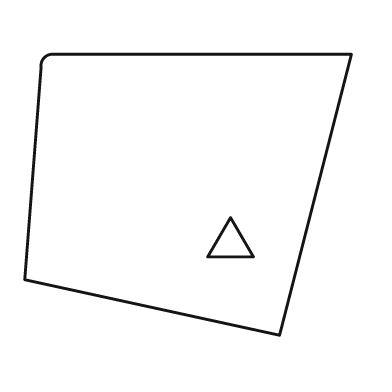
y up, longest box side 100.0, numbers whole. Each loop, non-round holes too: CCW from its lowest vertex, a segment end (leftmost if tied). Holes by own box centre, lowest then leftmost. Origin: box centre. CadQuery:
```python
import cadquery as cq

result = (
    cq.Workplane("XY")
    .moveTo(28.0, -43.0)
    .lineTo(50.0, 43.0)
    .lineTo(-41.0, 43.0)
    .threePointArc((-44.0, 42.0), (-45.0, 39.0))
    .lineTo(-50.0, -26.0)
    .close()
    .moveTo(6.0, -19.0)
    .lineTo(20.0, -19.0)
    .lineTo(13.0, -7.0)
    .close()
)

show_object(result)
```